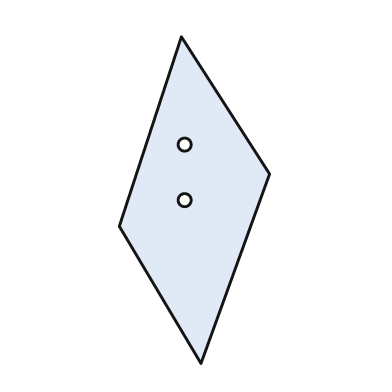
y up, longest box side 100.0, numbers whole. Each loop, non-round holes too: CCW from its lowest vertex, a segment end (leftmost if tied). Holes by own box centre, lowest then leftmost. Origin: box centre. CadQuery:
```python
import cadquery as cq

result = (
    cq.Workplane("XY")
    .moveTo(2.0, -50.0)
    .lineTo(23.0, 8.0)
    .lineTo(-4.0, 50.0)
    .lineTo(-23.0, -8.0)
    .close()
    .moveTo(-3.0, 0.0)
    .circle(2.0)
    .moveTo(-3.0, 17.0)
    .circle(2.0)
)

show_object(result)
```